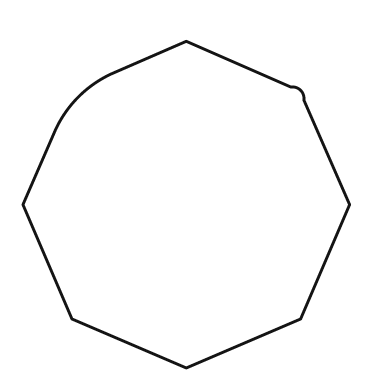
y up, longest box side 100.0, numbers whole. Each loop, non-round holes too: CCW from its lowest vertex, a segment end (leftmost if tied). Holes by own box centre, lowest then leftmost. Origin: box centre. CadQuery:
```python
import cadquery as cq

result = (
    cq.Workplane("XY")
    .moveTo(0.0, -50.0)
    .lineTo(35.0, -35.0)
    .lineTo(50.0, 0.0)
    .lineTo(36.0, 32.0)
    .threePointArc((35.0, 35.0), (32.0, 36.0))
    .lineTo(0.0, 50.0)
    .lineTo(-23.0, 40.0)
    .threePointArc((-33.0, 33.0), (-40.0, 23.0))
    .lineTo(-50.0, 0.0)
    .lineTo(-35.0, -35.0)
    .close()
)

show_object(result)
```